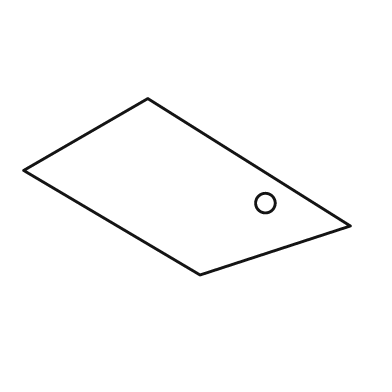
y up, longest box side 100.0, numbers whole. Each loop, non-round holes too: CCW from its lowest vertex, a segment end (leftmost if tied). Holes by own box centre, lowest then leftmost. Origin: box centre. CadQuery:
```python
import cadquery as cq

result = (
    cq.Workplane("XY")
    .moveTo(4.0, -27.0)
    .lineTo(50.0, -12.0)
    .lineTo(-12.0, 27.0)
    .lineTo(-50.0, 5.0)
    .close()
    .moveTo(24.0, -5.0)
    .circle(3.0)
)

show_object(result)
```